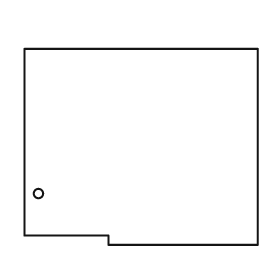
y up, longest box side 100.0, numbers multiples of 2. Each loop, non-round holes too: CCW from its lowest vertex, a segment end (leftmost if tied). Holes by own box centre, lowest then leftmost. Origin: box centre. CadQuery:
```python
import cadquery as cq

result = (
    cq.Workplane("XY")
    .moveTo(-14.0, -42.0)
    .lineTo(50.0, -42.0)
    .lineTo(50.0, 42.0)
    .lineTo(-50.0, 42.0)
    .lineTo(-50.0, -38.0)
    .lineTo(-14.0, -38.0)
    .close()
    .moveTo(-44.0, -20.0)
    .circle(2.0)
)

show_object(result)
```